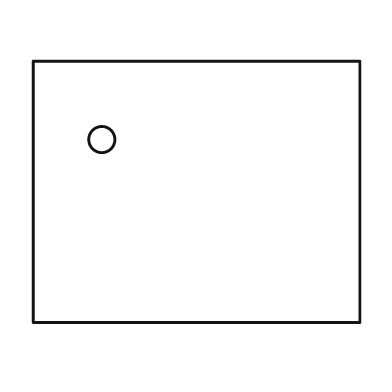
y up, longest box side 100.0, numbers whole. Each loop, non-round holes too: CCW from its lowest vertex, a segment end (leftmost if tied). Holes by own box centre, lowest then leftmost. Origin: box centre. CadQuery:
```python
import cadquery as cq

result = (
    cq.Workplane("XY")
    .moveTo(-50.0, -40.0)
    .lineTo(50.0, -40.0)
    .lineTo(50.0, 40.0)
    .lineTo(-50.0, 40.0)
    .close()
    .moveTo(-29.0, 16.0)
    .circle(4.0)
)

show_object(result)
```